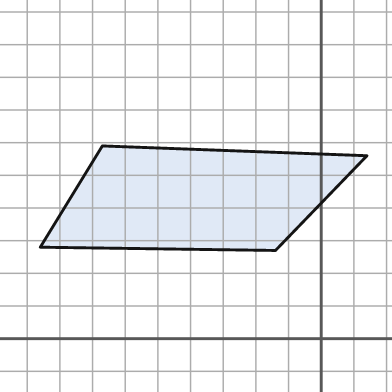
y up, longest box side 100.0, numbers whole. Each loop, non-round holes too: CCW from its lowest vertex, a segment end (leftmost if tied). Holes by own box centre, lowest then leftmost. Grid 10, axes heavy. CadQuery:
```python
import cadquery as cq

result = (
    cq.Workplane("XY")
    .moveTo(-14.0, 27.0)
    .lineTo(14.0, 56.0)
    .lineTo(-67.0, 59.0)
    .lineTo(-86.0, 28.0)
    .close()
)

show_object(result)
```